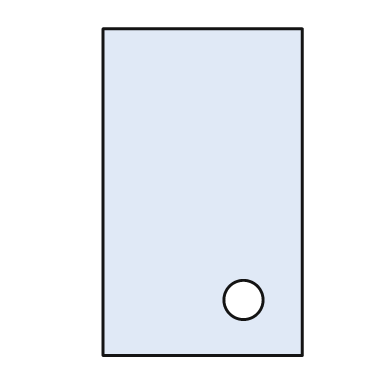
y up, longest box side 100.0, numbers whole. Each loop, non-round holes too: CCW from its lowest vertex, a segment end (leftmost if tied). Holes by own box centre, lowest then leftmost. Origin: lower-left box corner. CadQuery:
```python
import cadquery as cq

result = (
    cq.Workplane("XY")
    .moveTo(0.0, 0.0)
    .lineTo(61.0, 0.0)
    .lineTo(61.0, 100.0)
    .lineTo(0.0, 100.0)
    .close()
    .moveTo(43.0, 17.0)
    .circle(6.0)
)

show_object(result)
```